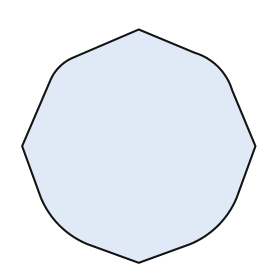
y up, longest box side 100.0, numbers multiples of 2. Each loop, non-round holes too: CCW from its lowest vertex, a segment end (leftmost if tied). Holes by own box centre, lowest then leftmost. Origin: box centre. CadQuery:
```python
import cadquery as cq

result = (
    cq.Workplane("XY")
    .moveTo(0.0, -50.0)
    .lineTo(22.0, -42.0)
    .threePointArc((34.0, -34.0), (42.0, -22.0))
    .lineTo(50.0, 0.0)
    .lineTo(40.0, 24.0)
    .threePointArc((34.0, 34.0), (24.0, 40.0))
    .lineTo(0.0, 50.0)
    .lineTo(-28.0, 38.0)
    .threePointArc((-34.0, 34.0), (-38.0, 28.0))
    .lineTo(-50.0, 0.0)
    .lineTo(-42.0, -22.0)
    .threePointArc((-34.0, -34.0), (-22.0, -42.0))
    .close()
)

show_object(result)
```